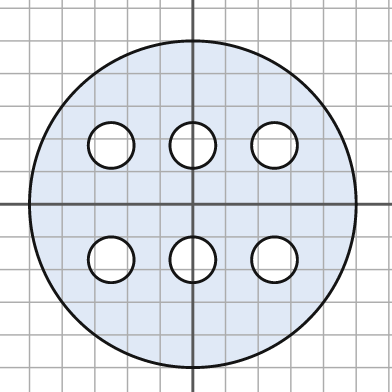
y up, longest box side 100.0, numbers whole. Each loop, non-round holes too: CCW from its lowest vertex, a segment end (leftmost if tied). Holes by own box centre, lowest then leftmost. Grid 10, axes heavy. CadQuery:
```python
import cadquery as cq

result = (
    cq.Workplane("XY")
    .moveTo(0.0, 0.0)
    .circle(50.0)
    .moveTo(-25.0, -17.0)
    .circle(7.0)
    .moveTo(0.0, -17.0)
    .circle(7.0)
    .moveTo(25.0, -17.0)
    .circle(7.0)
    .moveTo(-25.0, 18.0)
    .circle(7.0)
    .moveTo(0.0, 18.0)
    .circle(7.0)
    .moveTo(25.0, 18.0)
    .circle(7.0)
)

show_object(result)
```